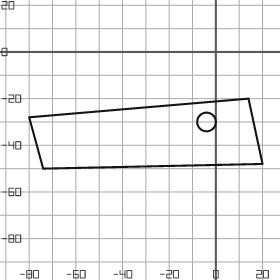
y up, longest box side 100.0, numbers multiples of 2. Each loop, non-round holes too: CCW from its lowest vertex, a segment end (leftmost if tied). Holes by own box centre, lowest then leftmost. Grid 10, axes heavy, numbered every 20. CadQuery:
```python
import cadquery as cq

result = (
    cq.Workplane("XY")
    .moveTo(-74.0, -50.0)
    .lineTo(20.0, -48.0)
    .lineTo(14.0, -20.0)
    .lineTo(-80.0, -28.0)
    .close()
    .moveTo(-4.0, -30.0)
    .circle(4.0)
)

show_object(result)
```